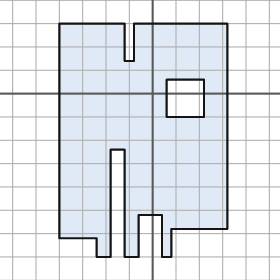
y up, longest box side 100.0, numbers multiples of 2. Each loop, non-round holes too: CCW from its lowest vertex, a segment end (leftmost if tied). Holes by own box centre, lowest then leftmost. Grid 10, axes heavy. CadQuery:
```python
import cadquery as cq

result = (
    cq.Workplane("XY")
    .moveTo(-24.0, -70.0)
    .lineTo(-18.0, -70.0)
    .lineTo(-18.0, -24.0)
    .lineTo(-12.0, -24.0)
    .lineTo(-12.0, -70.0)
    .lineTo(-6.0, -70.0)
    .lineTo(-6.0, -52.0)
    .lineTo(4.0, -52.0)
    .lineTo(4.0, -70.0)
    .lineTo(8.0, -70.0)
    .lineTo(8.0, -58.0)
    .lineTo(32.0, -58.0)
    .lineTo(32.0, 30.0)
    .lineTo(-8.0, 30.0)
    .lineTo(-8.0, 14.0)
    .lineTo(-12.0, 14.0)
    .lineTo(-12.0, 30.0)
    .lineTo(-40.0, 30.0)
    .lineTo(-40.0, -62.0)
    .lineTo(-24.0, -62.0)
    .close()
    .moveTo(6.0, -10.0)
    .lineTo(22.0, -10.0)
    .lineTo(22.0, 6.0)
    .lineTo(6.0, 6.0)
    .close()
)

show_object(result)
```